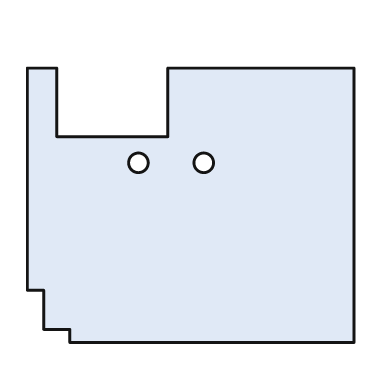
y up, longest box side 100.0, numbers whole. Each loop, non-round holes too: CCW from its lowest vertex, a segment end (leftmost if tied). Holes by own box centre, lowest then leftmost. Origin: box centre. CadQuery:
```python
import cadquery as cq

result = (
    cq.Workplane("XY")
    .moveTo(-37.0, -42.0)
    .lineTo(50.0, -42.0)
    .lineTo(50.0, 42.0)
    .lineTo(-7.0, 42.0)
    .lineTo(-7.0, 21.0)
    .lineTo(-41.0, 21.0)
    .lineTo(-41.0, 42.0)
    .lineTo(-50.0, 42.0)
    .lineTo(-50.0, -26.0)
    .lineTo(-45.0, -26.0)
    .lineTo(-45.0, -38.0)
    .lineTo(-37.0, -38.0)
    .close()
    .moveTo(-16.0, 13.0)
    .circle(3.0)
    .moveTo(4.0, 13.0)
    .circle(3.0)
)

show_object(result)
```